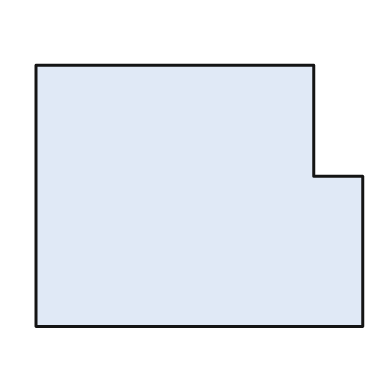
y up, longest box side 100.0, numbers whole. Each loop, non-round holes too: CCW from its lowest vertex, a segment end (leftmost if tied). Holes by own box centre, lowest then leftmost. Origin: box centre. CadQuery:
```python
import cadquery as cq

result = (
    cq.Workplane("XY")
    .moveTo(-50.0, -40.0)
    .lineTo(50.0, -40.0)
    .lineTo(50.0, 6.0)
    .lineTo(35.0, 6.0)
    .lineTo(35.0, 40.0)
    .lineTo(-50.0, 40.0)
    .close()
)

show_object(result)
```